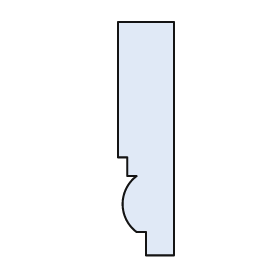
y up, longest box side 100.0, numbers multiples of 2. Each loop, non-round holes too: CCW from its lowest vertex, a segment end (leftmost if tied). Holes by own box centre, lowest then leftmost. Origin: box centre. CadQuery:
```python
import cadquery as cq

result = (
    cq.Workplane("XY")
    .moveTo(0.0, -50.0)
    .lineTo(12.0, -50.0)
    .lineTo(12.0, 50.0)
    .lineTo(-12.0, 50.0)
    .lineTo(-12.0, -8.0)
    .lineTo(-8.0, -8.0)
    .lineTo(-8.0, -16.0)
    .lineTo(-4.0, -16.0)
    .threePointArc((-10.0, -28.0), (-4.0, -40.0))
    .lineTo(0.0, -40.0)
    .close()
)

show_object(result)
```